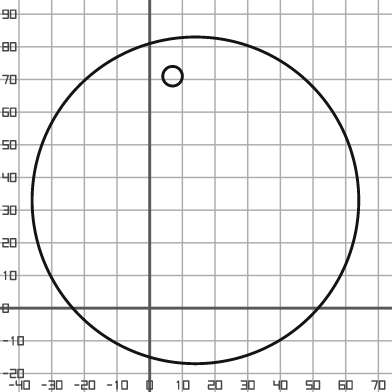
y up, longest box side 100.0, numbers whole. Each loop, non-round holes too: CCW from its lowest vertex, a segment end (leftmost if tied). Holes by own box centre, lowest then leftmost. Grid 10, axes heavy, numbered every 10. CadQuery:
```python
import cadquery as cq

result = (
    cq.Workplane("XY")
    .moveTo(14.0, 33.0)
    .circle(50.0)
    .moveTo(7.0, 71.0)
    .circle(3.0)
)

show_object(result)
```